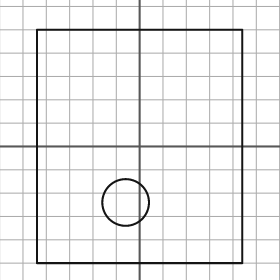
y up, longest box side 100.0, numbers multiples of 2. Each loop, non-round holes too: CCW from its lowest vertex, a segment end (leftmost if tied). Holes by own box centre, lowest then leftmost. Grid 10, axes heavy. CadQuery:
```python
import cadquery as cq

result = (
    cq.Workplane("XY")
    .moveTo(-44.0, -50.0)
    .lineTo(44.0, -50.0)
    .lineTo(44.0, 50.0)
    .lineTo(-44.0, 50.0)
    .close()
    .moveTo(-6.0, -24.0)
    .circle(10.0)
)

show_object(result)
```